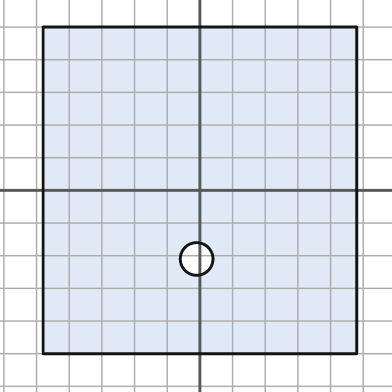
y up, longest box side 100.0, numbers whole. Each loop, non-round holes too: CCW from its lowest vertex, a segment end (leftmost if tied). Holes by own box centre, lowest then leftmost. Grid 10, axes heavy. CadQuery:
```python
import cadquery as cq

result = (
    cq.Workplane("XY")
    .moveTo(-48.0, -50.0)
    .lineTo(48.0, -50.0)
    .lineTo(48.0, 50.0)
    .lineTo(-48.0, 50.0)
    .close()
    .moveTo(-1.0, -21.0)
    .circle(5.0)
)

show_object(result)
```